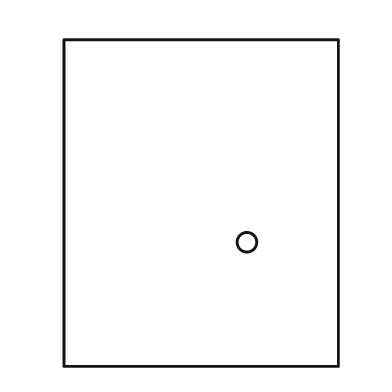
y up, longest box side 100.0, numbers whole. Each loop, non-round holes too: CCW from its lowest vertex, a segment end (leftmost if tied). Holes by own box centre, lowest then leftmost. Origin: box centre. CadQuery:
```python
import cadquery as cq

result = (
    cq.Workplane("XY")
    .moveTo(-42.0, -50.0)
    .lineTo(42.0, -50.0)
    .lineTo(42.0, 50.0)
    .lineTo(-42.0, 50.0)
    .close()
    .moveTo(14.0, -12.0)
    .circle(3.0)
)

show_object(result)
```